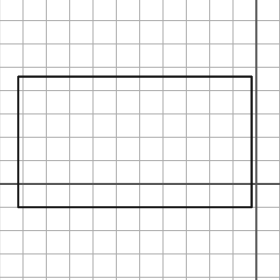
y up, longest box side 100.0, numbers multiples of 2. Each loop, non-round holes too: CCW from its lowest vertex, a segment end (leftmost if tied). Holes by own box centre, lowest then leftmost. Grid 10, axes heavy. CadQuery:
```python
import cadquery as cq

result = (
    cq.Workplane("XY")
    .moveTo(-102.0, -10.0)
    .lineTo(-2.0, -10.0)
    .lineTo(-2.0, 46.0)
    .lineTo(-102.0, 46.0)
    .close()
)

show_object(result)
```